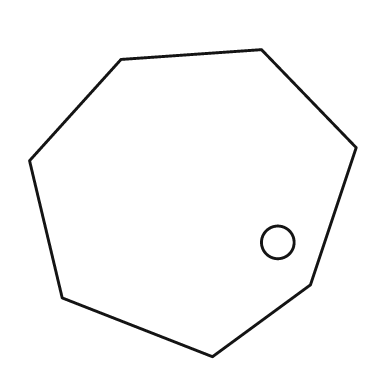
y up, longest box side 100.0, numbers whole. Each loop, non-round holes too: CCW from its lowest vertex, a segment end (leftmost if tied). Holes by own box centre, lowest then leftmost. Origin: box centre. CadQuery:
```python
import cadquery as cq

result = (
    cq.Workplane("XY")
    .moveTo(6.0, -47.0)
    .lineTo(36.0, -25.0)
    .lineTo(50.0, 17.0)
    .lineTo(21.0, 47.0)
    .lineTo(-22.0, 44.0)
    .lineTo(-50.0, 13.0)
    .lineTo(-40.0, -29.0)
    .close()
    .moveTo(26.0, -12.0)
    .circle(5.0)
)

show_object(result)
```